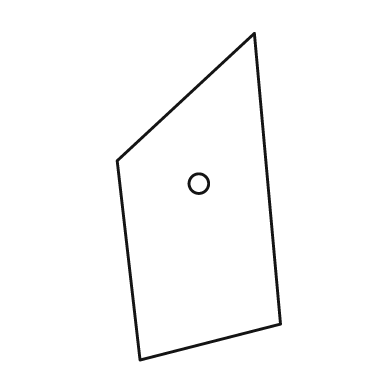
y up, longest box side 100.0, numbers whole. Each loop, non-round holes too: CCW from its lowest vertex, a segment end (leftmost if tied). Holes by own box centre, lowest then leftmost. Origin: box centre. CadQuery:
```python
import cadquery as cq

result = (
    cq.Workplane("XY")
    .moveTo(-18.0, -50.0)
    .lineTo(25.0, -39.0)
    .lineTo(17.0, 50.0)
    .lineTo(-25.0, 11.0)
    .close()
    .moveTo(0.0, 4.0)
    .circle(3.0)
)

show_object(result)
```